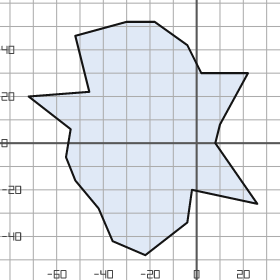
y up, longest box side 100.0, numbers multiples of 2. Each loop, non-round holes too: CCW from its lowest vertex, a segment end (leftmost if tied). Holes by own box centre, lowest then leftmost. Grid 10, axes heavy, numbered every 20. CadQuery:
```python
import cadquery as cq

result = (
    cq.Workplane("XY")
    .moveTo(-22.0, -48.0)
    .lineTo(-4.0, -34.0)
    .lineTo(-2.0, -20.0)
    .lineTo(26.0, -26.0)
    .lineTo(8.0, 0.0)
    .lineTo(10.0, 8.0)
    .lineTo(22.0, 30.0)
    .lineTo(2.0, 30.0)
    .lineTo(-4.0, 42.0)
    .lineTo(-18.0, 52.0)
    .lineTo(-30.0, 52.0)
    .lineTo(-52.0, 46.0)
    .lineTo(-46.0, 22.0)
    .lineTo(-72.0, 20.0)
    .lineTo(-54.0, 6.0)
    .lineTo(-56.0, -6.0)
    .lineTo(-52.0, -16.0)
    .lineTo(-42.0, -28.0)
    .lineTo(-36.0, -42.0)
    .close()
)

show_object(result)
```